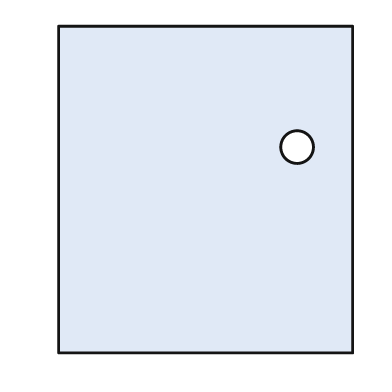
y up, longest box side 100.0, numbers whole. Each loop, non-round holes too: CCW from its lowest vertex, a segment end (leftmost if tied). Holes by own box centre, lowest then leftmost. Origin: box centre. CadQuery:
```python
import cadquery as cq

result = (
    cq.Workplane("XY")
    .moveTo(-45.0, -50.0)
    .lineTo(45.0, -50.0)
    .lineTo(45.0, 50.0)
    .lineTo(-45.0, 50.0)
    .close()
    .moveTo(28.0, 13.0)
    .circle(5.0)
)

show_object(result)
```